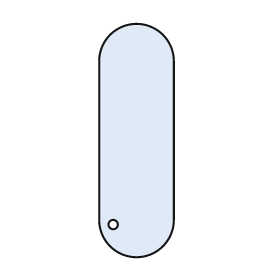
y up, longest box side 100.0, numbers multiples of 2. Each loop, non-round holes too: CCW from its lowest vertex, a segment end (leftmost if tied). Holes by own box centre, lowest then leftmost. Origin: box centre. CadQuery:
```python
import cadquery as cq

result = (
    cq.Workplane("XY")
    .moveTo(-16.0, -34.0)
    .threePointArc((0.0, -50.0), (16.0, -34.0))
    .lineTo(16.0, 34.0)
    .threePointArc((0.0, 50.0), (-16.0, 34.0))
    .close()
    .moveTo(-10.0, -36.0)
    .circle(2.0)
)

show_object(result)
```